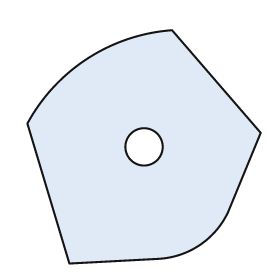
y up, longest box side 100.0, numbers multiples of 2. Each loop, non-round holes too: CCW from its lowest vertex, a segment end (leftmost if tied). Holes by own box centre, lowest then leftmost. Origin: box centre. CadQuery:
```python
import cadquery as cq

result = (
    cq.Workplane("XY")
    .moveTo(-32.0, -50.0)
    .lineTo(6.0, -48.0)
    .threePointArc((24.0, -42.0), (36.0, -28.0))
    .lineTo(50.0, 6.0)
    .lineTo(12.0, 50.0)
    .threePointArc((-24.0, 38.0), (-50.0, 10.0))
    .close()
    .moveTo(0.0, 0.0)
    .circle(8.0)
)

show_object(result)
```